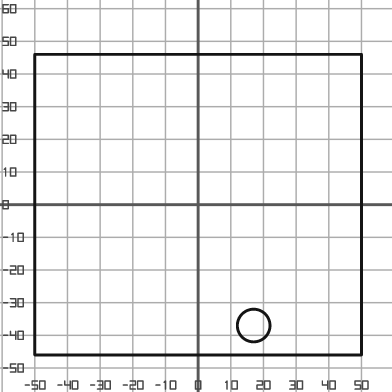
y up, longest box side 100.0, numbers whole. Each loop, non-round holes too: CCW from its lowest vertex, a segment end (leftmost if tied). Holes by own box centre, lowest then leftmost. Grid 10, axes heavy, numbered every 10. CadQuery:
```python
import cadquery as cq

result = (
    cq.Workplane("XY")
    .moveTo(-50.0, -46.0)
    .lineTo(50.0, -46.0)
    .lineTo(50.0, 46.0)
    .lineTo(-50.0, 46.0)
    .close()
    .moveTo(17.0, -37.0)
    .circle(5.0)
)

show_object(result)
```